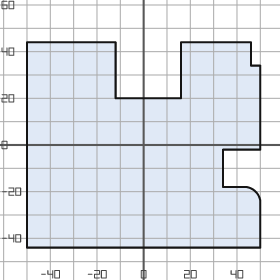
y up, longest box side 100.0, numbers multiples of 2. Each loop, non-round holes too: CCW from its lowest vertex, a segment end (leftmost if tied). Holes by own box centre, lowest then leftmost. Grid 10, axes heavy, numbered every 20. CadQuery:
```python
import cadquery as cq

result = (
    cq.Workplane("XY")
    .moveTo(-50.0, -44.0)
    .lineTo(50.0, -44.0)
    .lineTo(50.0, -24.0)
    .threePointArc((48.0, -20.0), (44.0, -18.0))
    .lineTo(34.0, -18.0)
    .lineTo(34.0, -2.0)
    .lineTo(50.0, -2.0)
    .lineTo(50.0, 34.0)
    .lineTo(46.0, 34.0)
    .lineTo(46.0, 44.0)
    .lineTo(16.0, 44.0)
    .lineTo(16.0, 20.0)
    .lineTo(-12.0, 20.0)
    .lineTo(-12.0, 44.0)
    .lineTo(-50.0, 44.0)
    .close()
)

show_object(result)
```